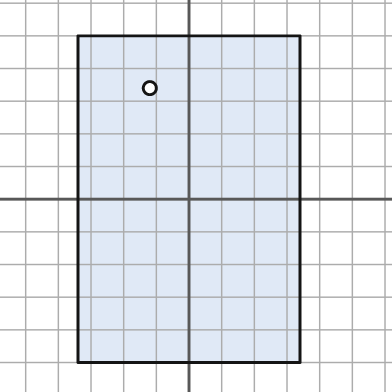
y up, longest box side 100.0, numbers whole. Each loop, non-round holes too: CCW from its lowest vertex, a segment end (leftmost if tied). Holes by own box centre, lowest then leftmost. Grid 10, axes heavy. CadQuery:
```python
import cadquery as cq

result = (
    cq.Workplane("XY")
    .moveTo(-34.0, -50.0)
    .lineTo(34.0, -50.0)
    .lineTo(34.0, 50.0)
    .lineTo(-34.0, 50.0)
    .close()
    .moveTo(-12.0, 34.0)
    .circle(2.0)
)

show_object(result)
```